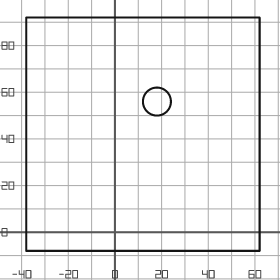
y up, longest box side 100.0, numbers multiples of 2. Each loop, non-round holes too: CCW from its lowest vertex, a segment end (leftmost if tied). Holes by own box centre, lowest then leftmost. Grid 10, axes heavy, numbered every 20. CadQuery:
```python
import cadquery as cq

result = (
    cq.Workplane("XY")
    .moveTo(-38.0, -8.0)
    .lineTo(62.0, -8.0)
    .lineTo(62.0, 92.0)
    .lineTo(-38.0, 92.0)
    .close()
    .moveTo(18.0, 56.0)
    .circle(6.0)
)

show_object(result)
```